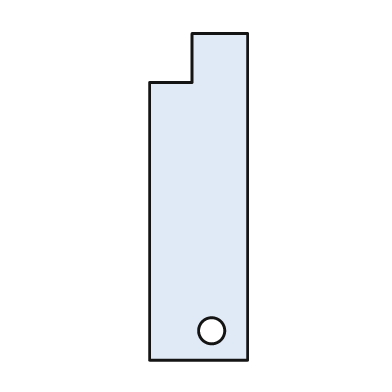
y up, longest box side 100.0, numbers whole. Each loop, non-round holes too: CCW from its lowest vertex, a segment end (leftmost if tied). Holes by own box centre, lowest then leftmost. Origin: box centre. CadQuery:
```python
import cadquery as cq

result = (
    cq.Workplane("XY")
    .moveTo(-15.0, -50.0)
    .lineTo(15.0, -50.0)
    .lineTo(15.0, 50.0)
    .lineTo(-2.0, 50.0)
    .lineTo(-2.0, 35.0)
    .lineTo(-15.0, 35.0)
    .close()
    .moveTo(4.0, -41.0)
    .circle(4.0)
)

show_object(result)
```